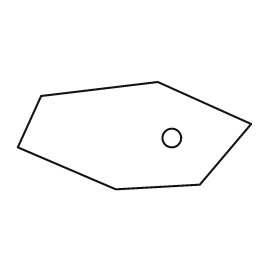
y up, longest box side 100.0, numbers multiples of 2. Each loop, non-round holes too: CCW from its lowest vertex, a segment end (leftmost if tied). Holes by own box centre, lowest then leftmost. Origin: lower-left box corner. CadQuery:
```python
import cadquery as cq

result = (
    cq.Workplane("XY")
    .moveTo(42.0, 0.0)
    .lineTo(78.0, 2.0)
    .lineTo(100.0, 28.0)
    .lineTo(60.0, 46.0)
    .lineTo(10.0, 40.0)
    .lineTo(0.0, 18.0)
    .close()
    .moveTo(66.0, 22.0)
    .circle(4.0)
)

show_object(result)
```